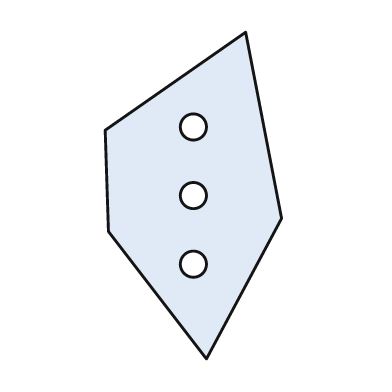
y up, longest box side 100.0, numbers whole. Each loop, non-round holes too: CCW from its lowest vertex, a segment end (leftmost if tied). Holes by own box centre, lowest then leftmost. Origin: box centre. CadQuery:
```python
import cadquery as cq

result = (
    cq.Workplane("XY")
    .moveTo(4.0, -50.0)
    .lineTo(27.0, -7.0)
    .lineTo(16.0, 50.0)
    .lineTo(-27.0, 20.0)
    .lineTo(-26.0, -11.0)
    .close()
    .moveTo(0.0, -21.0)
    .circle(4.0)
    .moveTo(0.0, 0.0)
    .circle(4.0)
    .moveTo(0.0, 21.0)
    .circle(4.0)
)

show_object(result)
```